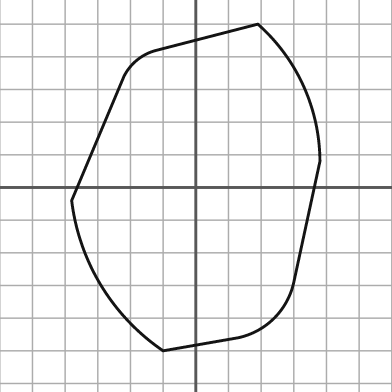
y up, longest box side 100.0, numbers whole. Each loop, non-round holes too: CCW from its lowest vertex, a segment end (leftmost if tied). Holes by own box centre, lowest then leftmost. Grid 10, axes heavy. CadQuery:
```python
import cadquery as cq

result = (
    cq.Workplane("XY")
    .moveTo(-10.0, -50.0)
    .lineTo(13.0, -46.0)
    .threePointArc((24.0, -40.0), (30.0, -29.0))
    .lineTo(38.0, 8.0)
    .threePointArc((33.0, 31.0), (19.0, 50.0))
    .lineTo(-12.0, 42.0)
    .threePointArc((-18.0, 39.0), (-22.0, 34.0))
    .lineTo(-38.0, -4.0)
    .threePointArc((-29.0, -30.0), (-10.0, -50.0))
    .close()
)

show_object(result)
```